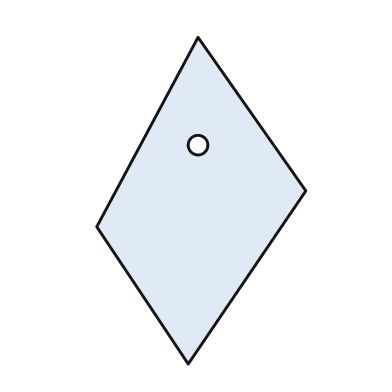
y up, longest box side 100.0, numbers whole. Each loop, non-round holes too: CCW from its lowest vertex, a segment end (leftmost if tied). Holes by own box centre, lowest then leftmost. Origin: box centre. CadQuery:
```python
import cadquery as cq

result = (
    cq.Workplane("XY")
    .moveTo(-4.0, -50.0)
    .lineTo(32.0, 3.0)
    .lineTo(-1.0, 50.0)
    .lineTo(-32.0, -8.0)
    .close()
    .moveTo(-1.0, 17.0)
    .circle(3.0)
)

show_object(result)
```